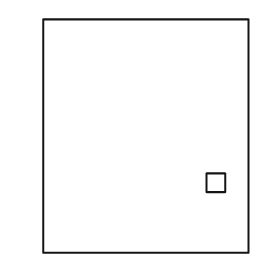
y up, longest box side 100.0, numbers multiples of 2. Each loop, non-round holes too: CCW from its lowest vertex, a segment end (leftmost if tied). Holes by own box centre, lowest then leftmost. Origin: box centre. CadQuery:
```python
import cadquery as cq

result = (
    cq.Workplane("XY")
    .moveTo(-44.0, -50.0)
    .lineTo(44.0, -50.0)
    .lineTo(44.0, 50.0)
    .lineTo(-44.0, 50.0)
    .close()
    .moveTo(26.0, -24.0)
    .lineTo(34.0, -24.0)
    .lineTo(34.0, -16.0)
    .lineTo(26.0, -16.0)
    .close()
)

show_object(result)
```